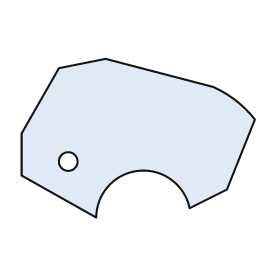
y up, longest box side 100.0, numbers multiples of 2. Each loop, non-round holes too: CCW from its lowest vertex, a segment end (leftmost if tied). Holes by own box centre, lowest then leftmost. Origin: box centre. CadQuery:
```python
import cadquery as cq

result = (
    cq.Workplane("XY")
    .moveTo(-18.0, -34.0)
    .threePointArc((0.0, -14.0), (22.0, -30.0))
    .lineTo(38.0, -22.0)
    .lineTo(50.0, 8.0)
    .threePointArc((42.0, 16.0), (32.0, 22.0))
    .lineTo(-14.0, 34.0)
    .lineTo(-34.0, 30.0)
    .lineTo(-50.0, 2.0)
    .lineTo(-50.0, -16.0)
    .close()
    .moveTo(-30.0, -10.0)
    .circle(4.0)
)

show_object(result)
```